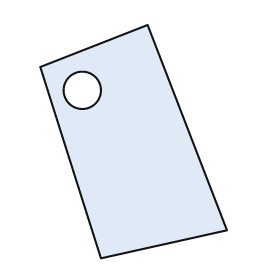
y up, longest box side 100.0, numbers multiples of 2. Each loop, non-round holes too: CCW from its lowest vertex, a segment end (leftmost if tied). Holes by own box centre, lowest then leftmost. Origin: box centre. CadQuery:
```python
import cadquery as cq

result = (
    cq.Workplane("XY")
    .moveTo(-14.0, -50.0)
    .lineTo(40.0, -38.0)
    .lineTo(6.0, 50.0)
    .lineTo(-40.0, 32.0)
    .close()
    .moveTo(-22.0, 22.0)
    .circle(8.0)
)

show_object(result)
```